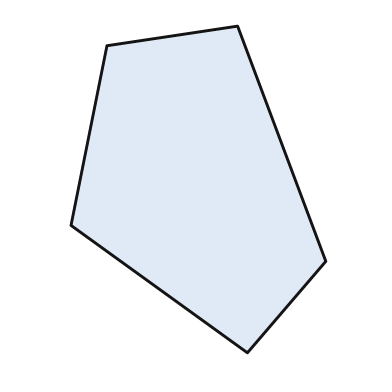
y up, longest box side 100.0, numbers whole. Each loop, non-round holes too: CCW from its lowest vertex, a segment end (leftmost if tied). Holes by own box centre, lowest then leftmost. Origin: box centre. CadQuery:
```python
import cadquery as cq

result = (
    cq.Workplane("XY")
    .moveTo(15.0, -50.0)
    .lineTo(39.0, -22.0)
    .lineTo(12.0, 50.0)
    .lineTo(-28.0, 44.0)
    .lineTo(-39.0, -11.0)
    .close()
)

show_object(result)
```